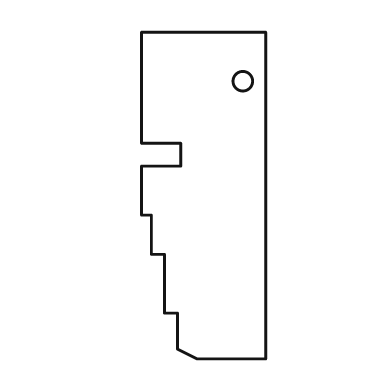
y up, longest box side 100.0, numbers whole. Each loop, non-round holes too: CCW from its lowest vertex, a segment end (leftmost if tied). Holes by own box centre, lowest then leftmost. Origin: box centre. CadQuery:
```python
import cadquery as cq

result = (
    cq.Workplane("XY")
    .moveTo(-2.0, -50.0)
    .lineTo(19.0, -50.0)
    .lineTo(19.0, 50.0)
    .lineTo(-19.0, 50.0)
    .lineTo(-19.0, 16.0)
    .lineTo(-7.0, 16.0)
    .lineTo(-7.0, 9.0)
    .lineTo(-19.0, 9.0)
    .lineTo(-19.0, -6.0)
    .lineTo(-16.0, -6.0)
    .lineTo(-16.0, -18.0)
    .lineTo(-12.0, -18.0)
    .lineTo(-12.0, -36.0)
    .lineTo(-8.0, -36.0)
    .lineTo(-8.0, -47.0)
    .close()
    .moveTo(12.0, 35.0)
    .circle(3.0)
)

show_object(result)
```